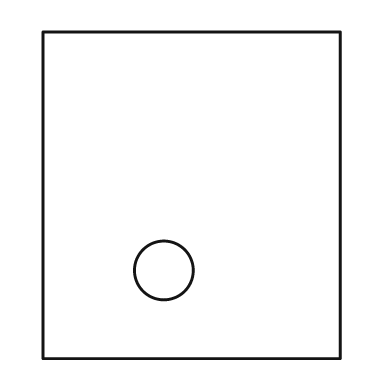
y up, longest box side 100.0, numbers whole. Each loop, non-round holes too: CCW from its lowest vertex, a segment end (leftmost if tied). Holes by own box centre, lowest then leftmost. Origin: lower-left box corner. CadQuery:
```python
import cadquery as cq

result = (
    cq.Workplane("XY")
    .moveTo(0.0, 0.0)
    .lineTo(91.0, 0.0)
    .lineTo(91.0, 100.0)
    .lineTo(0.0, 100.0)
    .close()
    .moveTo(37.0, 27.0)
    .circle(9.0)
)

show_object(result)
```